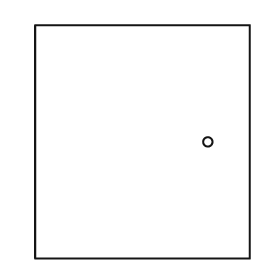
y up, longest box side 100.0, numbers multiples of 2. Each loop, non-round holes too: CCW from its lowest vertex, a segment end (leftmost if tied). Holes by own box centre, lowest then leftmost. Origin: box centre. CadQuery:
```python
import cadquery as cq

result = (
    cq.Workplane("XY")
    .moveTo(-46.0, -50.0)
    .lineTo(46.0, -50.0)
    .lineTo(46.0, 50.0)
    .lineTo(-46.0, 50.0)
    .close()
    .moveTo(28.0, 0.0)
    .circle(2.0)
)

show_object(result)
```